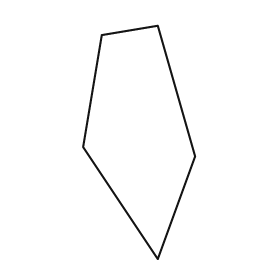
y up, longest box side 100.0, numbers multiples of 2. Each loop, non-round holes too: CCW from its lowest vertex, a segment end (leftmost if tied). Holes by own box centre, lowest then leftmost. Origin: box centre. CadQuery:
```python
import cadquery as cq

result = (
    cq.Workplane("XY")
    .moveTo(8.0, -50.0)
    .lineTo(24.0, -6.0)
    .lineTo(8.0, 50.0)
    .lineTo(-16.0, 46.0)
    .lineTo(-24.0, -2.0)
    .close()
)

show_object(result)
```